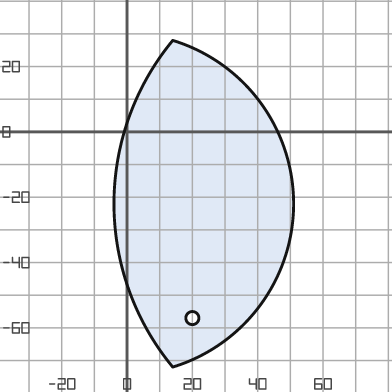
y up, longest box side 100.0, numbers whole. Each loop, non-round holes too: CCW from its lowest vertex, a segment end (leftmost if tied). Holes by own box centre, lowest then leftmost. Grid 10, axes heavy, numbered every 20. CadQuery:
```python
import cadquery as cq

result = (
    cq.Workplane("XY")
    .moveTo(14.0, -72.0)
    .threePointArc((51.0, -22.0), (14.0, 28.0))
    .threePointArc((-4.0, -22.0), (14.0, -72.0))
    .close()
    .moveTo(20.0, -57.0)
    .circle(2.0)
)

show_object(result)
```